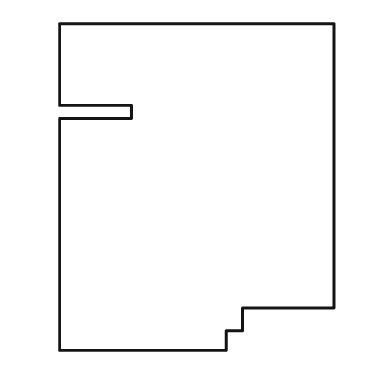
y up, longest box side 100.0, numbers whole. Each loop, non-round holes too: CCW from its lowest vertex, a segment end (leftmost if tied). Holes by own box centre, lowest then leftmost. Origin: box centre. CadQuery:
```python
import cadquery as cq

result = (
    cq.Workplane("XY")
    .moveTo(-42.0, -50.0)
    .lineTo(9.0, -50.0)
    .lineTo(9.0, -44.0)
    .lineTo(14.0, -44.0)
    .lineTo(14.0, -37.0)
    .lineTo(42.0, -37.0)
    .lineTo(42.0, 50.0)
    .lineTo(-42.0, 50.0)
    .lineTo(-42.0, 25.0)
    .lineTo(-20.0, 25.0)
    .lineTo(-20.0, 21.0)
    .lineTo(-42.0, 21.0)
    .close()
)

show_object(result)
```